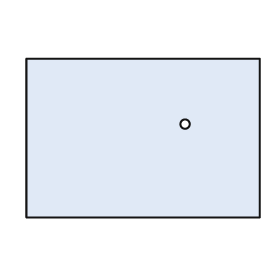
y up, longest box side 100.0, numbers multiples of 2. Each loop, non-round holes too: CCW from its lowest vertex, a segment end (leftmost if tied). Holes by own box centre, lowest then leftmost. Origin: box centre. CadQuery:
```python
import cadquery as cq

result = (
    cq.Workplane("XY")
    .moveTo(-50.0, -34.0)
    .lineTo(50.0, -34.0)
    .lineTo(50.0, 34.0)
    .lineTo(-50.0, 34.0)
    .close()
    .moveTo(18.0, 6.0)
    .circle(2.0)
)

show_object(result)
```